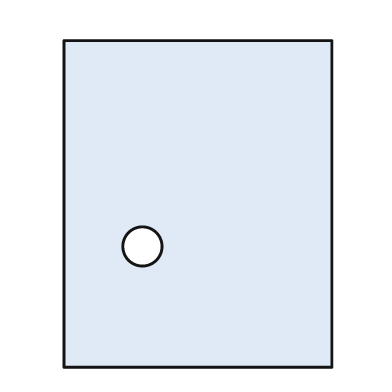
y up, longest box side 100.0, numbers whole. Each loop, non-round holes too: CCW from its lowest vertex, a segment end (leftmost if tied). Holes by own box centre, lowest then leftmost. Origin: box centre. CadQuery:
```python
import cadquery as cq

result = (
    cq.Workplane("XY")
    .moveTo(-41.0, -50.0)
    .lineTo(41.0, -50.0)
    .lineTo(41.0, 50.0)
    .lineTo(-41.0, 50.0)
    .close()
    .moveTo(-17.0, -13.0)
    .circle(6.0)
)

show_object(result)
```